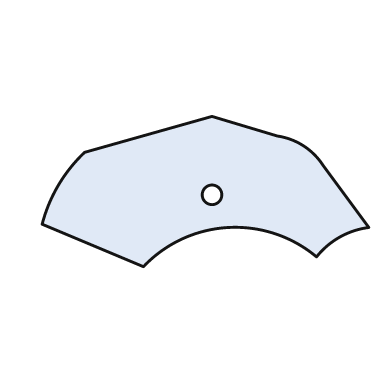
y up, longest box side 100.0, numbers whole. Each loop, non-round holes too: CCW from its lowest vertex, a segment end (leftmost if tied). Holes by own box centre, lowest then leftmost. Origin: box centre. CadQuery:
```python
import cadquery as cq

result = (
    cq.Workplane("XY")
    .moveTo(-19.0, -23.0)
    .threePointArc((7.0, -11.0), (34.0, -20.0))
    .threePointArc((41.0, -14.0), (50.0, -11.0))
    .lineTo(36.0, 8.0)
    .threePointArc((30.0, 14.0), (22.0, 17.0))
    .lineTo(2.0, 23.0)
    .lineTo(-37.0, 12.0)
    .threePointArc((-45.0, 2.0), (-50.0, -10.0))
    .close()
    .moveTo(2.0, -1.0)
    .circle(3.0)
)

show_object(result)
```